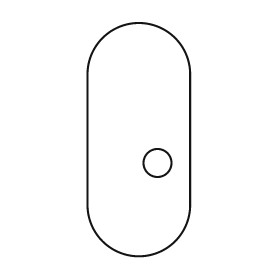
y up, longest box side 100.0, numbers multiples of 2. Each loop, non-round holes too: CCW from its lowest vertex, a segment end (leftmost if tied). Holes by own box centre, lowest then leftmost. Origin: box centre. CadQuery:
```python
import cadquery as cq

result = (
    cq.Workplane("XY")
    .moveTo(-22.0, -28.0)
    .threePointArc((0.0, -50.0), (22.0, -28.0))
    .lineTo(22.0, 28.0)
    .threePointArc((0.0, 50.0), (-22.0, 28.0))
    .close()
    .moveTo(8.0, -10.0)
    .circle(6.0)
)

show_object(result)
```